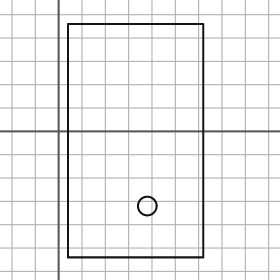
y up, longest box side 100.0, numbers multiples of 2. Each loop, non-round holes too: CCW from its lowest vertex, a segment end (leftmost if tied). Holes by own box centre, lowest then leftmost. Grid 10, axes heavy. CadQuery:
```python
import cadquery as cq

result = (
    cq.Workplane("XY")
    .moveTo(4.0, -54.0)
    .lineTo(62.0, -54.0)
    .lineTo(62.0, 46.0)
    .lineTo(4.0, 46.0)
    .close()
    .moveTo(38.0, -32.0)
    .circle(4.0)
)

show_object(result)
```